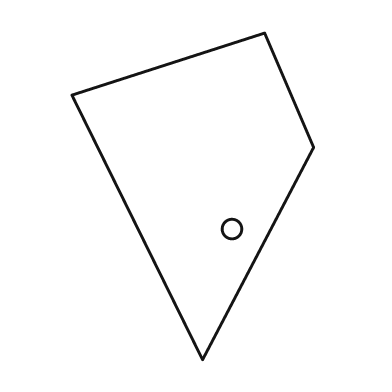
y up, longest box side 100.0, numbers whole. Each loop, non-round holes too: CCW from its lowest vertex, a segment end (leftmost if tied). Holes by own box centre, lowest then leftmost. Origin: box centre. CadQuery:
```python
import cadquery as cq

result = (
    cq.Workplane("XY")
    .moveTo(3.0, -50.0)
    .lineTo(37.0, 15.0)
    .lineTo(22.0, 50.0)
    .lineTo(-37.0, 31.0)
    .close()
    .moveTo(12.0, -10.0)
    .circle(3.0)
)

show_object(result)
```